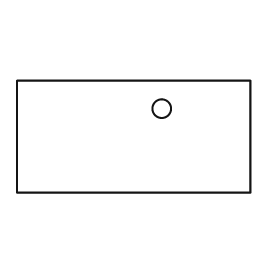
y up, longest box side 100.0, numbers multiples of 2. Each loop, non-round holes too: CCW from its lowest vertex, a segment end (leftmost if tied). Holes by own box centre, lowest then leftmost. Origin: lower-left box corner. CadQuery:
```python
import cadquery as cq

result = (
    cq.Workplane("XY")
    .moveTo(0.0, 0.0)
    .lineTo(100.0, 0.0)
    .lineTo(100.0, 48.0)
    .lineTo(0.0, 48.0)
    .close()
    .moveTo(62.0, 36.0)
    .circle(4.0)
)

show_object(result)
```